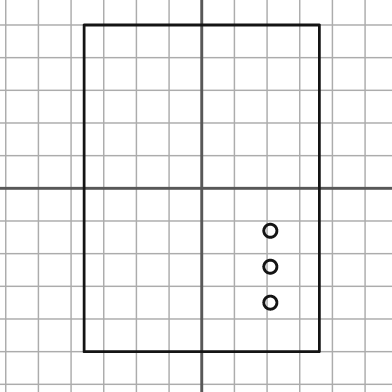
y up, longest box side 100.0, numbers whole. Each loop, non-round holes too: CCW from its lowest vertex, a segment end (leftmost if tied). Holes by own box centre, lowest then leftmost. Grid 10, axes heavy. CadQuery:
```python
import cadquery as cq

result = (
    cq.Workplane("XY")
    .moveTo(-36.0, -50.0)
    .lineTo(36.0, -50.0)
    .lineTo(36.0, 50.0)
    .lineTo(-36.0, 50.0)
    .close()
    .moveTo(21.0, -35.0)
    .circle(2.0)
    .moveTo(21.0, -24.0)
    .circle(2.0)
    .moveTo(21.0, -13.0)
    .circle(2.0)
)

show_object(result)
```